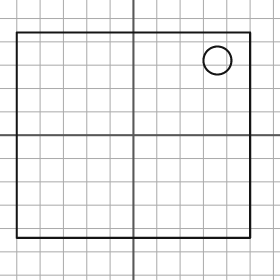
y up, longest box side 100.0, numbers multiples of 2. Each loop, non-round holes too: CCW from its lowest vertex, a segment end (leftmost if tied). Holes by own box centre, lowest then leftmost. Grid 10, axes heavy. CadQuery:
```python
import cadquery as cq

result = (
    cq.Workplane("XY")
    .moveTo(-50.0, -44.0)
    .lineTo(50.0, -44.0)
    .lineTo(50.0, 44.0)
    .lineTo(-50.0, 44.0)
    .close()
    .moveTo(36.0, 32.0)
    .circle(6.0)
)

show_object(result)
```